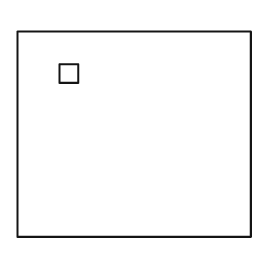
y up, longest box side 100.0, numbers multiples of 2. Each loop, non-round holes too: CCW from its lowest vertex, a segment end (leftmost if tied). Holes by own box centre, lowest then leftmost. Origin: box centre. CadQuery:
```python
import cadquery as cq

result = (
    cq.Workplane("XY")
    .moveTo(-50.0, -44.0)
    .lineTo(50.0, -44.0)
    .lineTo(50.0, 44.0)
    .lineTo(-50.0, 44.0)
    .close()
    .moveTo(-32.0, 22.0)
    .lineTo(-24.0, 22.0)
    .lineTo(-24.0, 30.0)
    .lineTo(-32.0, 30.0)
    .close()
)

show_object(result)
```